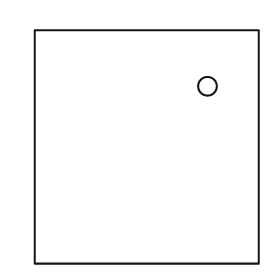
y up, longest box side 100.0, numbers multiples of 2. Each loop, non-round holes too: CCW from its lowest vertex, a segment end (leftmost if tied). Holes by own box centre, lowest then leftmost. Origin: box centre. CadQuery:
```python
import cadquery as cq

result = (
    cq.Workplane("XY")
    .moveTo(-48.0, -50.0)
    .lineTo(48.0, -50.0)
    .lineTo(48.0, 50.0)
    .lineTo(-48.0, 50.0)
    .close()
    .moveTo(26.0, 26.0)
    .circle(4.0)
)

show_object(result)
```